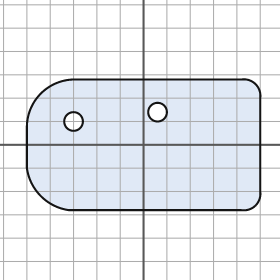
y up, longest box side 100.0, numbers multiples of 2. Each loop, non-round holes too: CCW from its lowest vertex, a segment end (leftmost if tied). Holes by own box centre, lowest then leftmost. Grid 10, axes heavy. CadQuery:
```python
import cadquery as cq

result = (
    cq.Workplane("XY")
    .moveTo(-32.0, -28.0)
    .lineTo(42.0, -28.0)
    .threePointArc((48.0, -26.0), (50.0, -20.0))
    .lineTo(50.0, 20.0)
    .threePointArc((48.0, 26.0), (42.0, 28.0))
    .lineTo(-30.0, 28.0)
    .threePointArc((-44.0, 22.0), (-50.0, 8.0))
    .lineTo(-50.0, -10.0)
    .threePointArc((-44.0, -22.0), (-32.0, -28.0))
    .close()
    .moveTo(-30.0, 10.0)
    .circle(4.0)
    .moveTo(6.0, 14.0)
    .circle(4.0)
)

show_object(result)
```